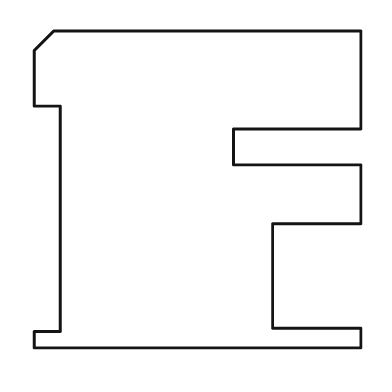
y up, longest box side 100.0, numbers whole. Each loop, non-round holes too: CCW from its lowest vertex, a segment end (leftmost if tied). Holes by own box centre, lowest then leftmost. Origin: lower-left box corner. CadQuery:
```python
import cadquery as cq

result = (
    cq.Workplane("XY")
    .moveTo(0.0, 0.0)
    .lineTo(100.0, 0.0)
    .lineTo(100.0, 6.0)
    .lineTo(73.0, 6.0)
    .lineTo(73.0, 38.0)
    .lineTo(100.0, 38.0)
    .lineTo(100.0, 56.0)
    .lineTo(61.0, 56.0)
    .lineTo(61.0, 67.0)
    .lineTo(100.0, 67.0)
    .lineTo(100.0, 97.0)
    .lineTo(6.0, 97.0)
    .lineTo(0.0, 91.0)
    .lineTo(0.0, 74.0)
    .lineTo(8.0, 74.0)
    .lineTo(8.0, 5.0)
    .lineTo(0.0, 5.0)
    .close()
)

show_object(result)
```